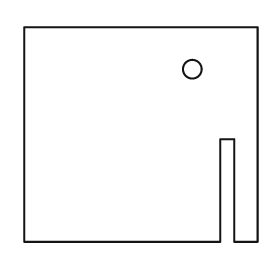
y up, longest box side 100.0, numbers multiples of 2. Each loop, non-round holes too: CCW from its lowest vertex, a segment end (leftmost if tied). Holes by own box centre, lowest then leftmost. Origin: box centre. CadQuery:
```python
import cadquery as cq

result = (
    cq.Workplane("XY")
    .moveTo(-50.0, -46.0)
    .lineTo(34.0, -46.0)
    .lineTo(34.0, -2.0)
    .lineTo(40.0, -2.0)
    .lineTo(40.0, -46.0)
    .lineTo(50.0, -46.0)
    .lineTo(50.0, 46.0)
    .lineTo(-50.0, 46.0)
    .close()
    .moveTo(22.0, 28.0)
    .circle(4.0)
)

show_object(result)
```